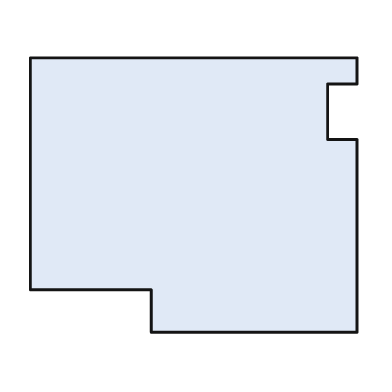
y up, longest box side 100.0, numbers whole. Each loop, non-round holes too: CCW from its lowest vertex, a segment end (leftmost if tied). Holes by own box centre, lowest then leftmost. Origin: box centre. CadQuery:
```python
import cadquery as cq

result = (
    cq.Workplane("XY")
    .moveTo(-13.0, -42.0)
    .lineTo(50.0, -42.0)
    .lineTo(50.0, 17.0)
    .lineTo(41.0, 17.0)
    .lineTo(41.0, 34.0)
    .lineTo(50.0, 34.0)
    .lineTo(50.0, 42.0)
    .lineTo(-50.0, 42.0)
    .lineTo(-50.0, -29.0)
    .lineTo(-13.0, -29.0)
    .close()
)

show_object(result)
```